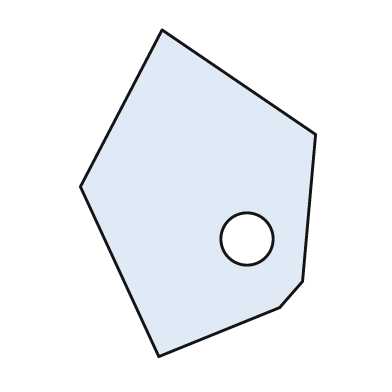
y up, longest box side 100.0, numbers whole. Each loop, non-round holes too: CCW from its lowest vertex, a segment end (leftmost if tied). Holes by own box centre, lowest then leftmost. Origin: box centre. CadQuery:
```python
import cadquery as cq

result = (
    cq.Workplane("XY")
    .moveTo(-12.0, -50.0)
    .lineTo(25.0, -35.0)
    .lineTo(32.0, -27.0)
    .lineTo(36.0, 18.0)
    .lineTo(-11.0, 50.0)
    .lineTo(-36.0, 2.0)
    .close()
    .moveTo(15.0, -14.0)
    .circle(8.0)
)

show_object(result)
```